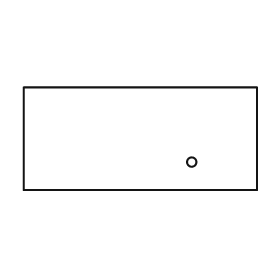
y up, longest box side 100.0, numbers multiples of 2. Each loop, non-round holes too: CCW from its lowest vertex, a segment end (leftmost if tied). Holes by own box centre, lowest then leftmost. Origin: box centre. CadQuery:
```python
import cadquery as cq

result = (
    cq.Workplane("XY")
    .moveTo(-50.0, -22.0)
    .lineTo(50.0, -22.0)
    .lineTo(50.0, 22.0)
    .lineTo(-50.0, 22.0)
    .close()
    .moveTo(22.0, -10.0)
    .circle(2.0)
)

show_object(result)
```